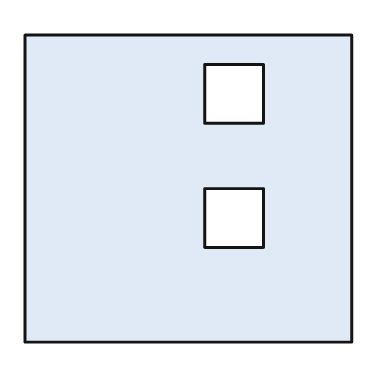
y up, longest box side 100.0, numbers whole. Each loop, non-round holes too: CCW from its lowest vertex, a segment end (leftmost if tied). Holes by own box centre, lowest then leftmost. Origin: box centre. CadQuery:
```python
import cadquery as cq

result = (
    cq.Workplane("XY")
    .moveTo(-50.0, -47.0)
    .lineTo(50.0, -47.0)
    .lineTo(50.0, 47.0)
    .lineTo(-50.0, 47.0)
    .close()
    .moveTo(5.0, -18.0)
    .lineTo(23.0, -18.0)
    .lineTo(23.0, 0.0)
    .lineTo(5.0, 0.0)
    .close()
    .moveTo(5.0, 20.0)
    .lineTo(23.0, 20.0)
    .lineTo(23.0, 38.0)
    .lineTo(5.0, 38.0)
    .close()
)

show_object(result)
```